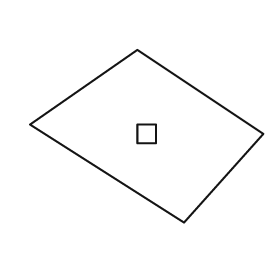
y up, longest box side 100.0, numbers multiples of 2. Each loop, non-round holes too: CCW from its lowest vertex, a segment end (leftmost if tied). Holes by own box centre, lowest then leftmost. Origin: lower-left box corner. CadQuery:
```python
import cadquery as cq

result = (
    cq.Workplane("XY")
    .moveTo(66.0, 0.0)
    .lineTo(100.0, 38.0)
    .lineTo(46.0, 74.0)
    .lineTo(0.0, 42.0)
    .close()
    .moveTo(46.0, 34.0)
    .lineTo(54.0, 34.0)
    .lineTo(54.0, 42.0)
    .lineTo(46.0, 42.0)
    .close()
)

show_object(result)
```